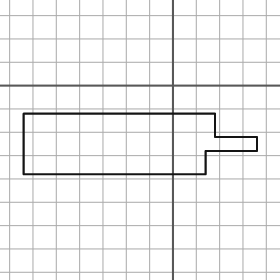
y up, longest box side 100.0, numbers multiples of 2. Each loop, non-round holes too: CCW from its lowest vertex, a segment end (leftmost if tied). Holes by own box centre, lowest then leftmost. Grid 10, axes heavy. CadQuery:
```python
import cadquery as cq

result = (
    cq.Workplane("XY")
    .moveTo(-64.0, -38.0)
    .lineTo(14.0, -38.0)
    .lineTo(14.0, -28.0)
    .lineTo(36.0, -28.0)
    .lineTo(36.0, -22.0)
    .lineTo(18.0, -22.0)
    .lineTo(18.0, -12.0)
    .lineTo(-64.0, -12.0)
    .close()
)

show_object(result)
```